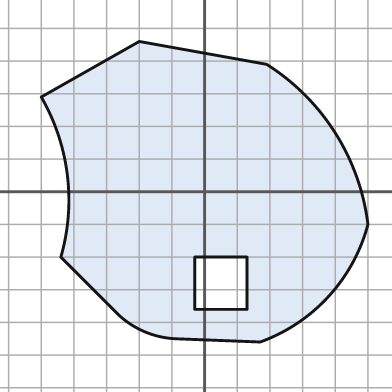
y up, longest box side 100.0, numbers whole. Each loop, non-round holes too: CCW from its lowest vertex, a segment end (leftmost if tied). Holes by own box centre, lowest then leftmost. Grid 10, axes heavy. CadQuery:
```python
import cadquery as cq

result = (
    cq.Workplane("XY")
    .moveTo(17.0, -46.0)
    .threePointArc((38.0, -32.0), (50.0, -10.0))
    .threePointArc((40.0, 18.0), (19.0, 39.0))
    .lineTo(-20.0, 46.0)
    .lineTo(-50.0, 29.0)
    .threePointArc((-42.0, 5.0), (-44.0, -20.0))
    .lineTo(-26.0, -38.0)
    .threePointArc((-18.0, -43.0), (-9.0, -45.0))
    .close()
    .moveTo(-3.0, -36.0)
    .lineTo(13.0, -36.0)
    .lineTo(13.0, -20.0)
    .lineTo(-3.0, -20.0)
    .close()
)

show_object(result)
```